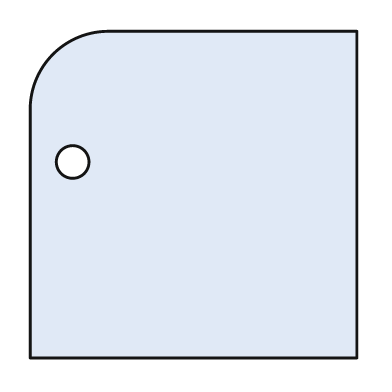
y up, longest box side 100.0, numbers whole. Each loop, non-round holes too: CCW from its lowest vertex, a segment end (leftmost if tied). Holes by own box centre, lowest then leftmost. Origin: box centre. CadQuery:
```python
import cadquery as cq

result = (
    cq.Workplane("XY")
    .moveTo(-50.0, -50.0)
    .lineTo(50.0, -50.0)
    .lineTo(50.0, 50.0)
    .lineTo(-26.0, 50.0)
    .threePointArc((-43.0, 43.0), (-50.0, 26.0))
    .close()
    .moveTo(-37.0, 10.0)
    .circle(5.0)
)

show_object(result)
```